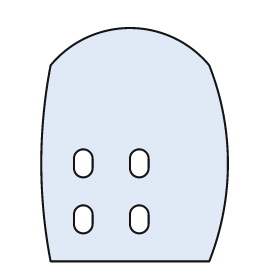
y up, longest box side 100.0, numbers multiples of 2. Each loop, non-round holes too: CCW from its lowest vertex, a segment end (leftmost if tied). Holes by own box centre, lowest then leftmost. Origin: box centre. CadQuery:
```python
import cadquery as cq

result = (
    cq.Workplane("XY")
    .moveTo(-36.0, -50.0)
    .lineTo(32.0, -50.0)
    .threePointArc((40.0, -8.0), (32.0, 34.0))
    .threePointArc((-2.0, 50.0), (-36.0, 34.0))
    .threePointArc((-40.0, -8.0), (-36.0, -50.0))
    .close()
    .moveTo(-26.0, -34.0)
    .threePointArc((-22.0, -38.0), (-18.0, -34.0))
    .lineTo(-18.0, -30.0)
    .threePointArc((-22.0, -26.0), (-26.0, -30.0))
    .close()
    .moveTo(-2.0, -34.0)
    .threePointArc((2.0, -38.0), (6.0, -34.0))
    .lineTo(6.0, -30.0)
    .threePointArc((2.0, -26.0), (-2.0, -30.0))
    .close()
    .moveTo(-26.0, -10.0)
    .threePointArc((-22.0, -14.0), (-18.0, -10.0))
    .lineTo(-18.0, -6.0)
    .threePointArc((-22.0, -2.0), (-26.0, -6.0))
    .close()
    .moveTo(-2.0, -10.0)
    .threePointArc((2.0, -14.0), (6.0, -10.0))
    .lineTo(6.0, -6.0)
    .threePointArc((2.0, -2.0), (-2.0, -6.0))
    .close()
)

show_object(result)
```